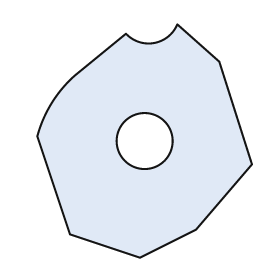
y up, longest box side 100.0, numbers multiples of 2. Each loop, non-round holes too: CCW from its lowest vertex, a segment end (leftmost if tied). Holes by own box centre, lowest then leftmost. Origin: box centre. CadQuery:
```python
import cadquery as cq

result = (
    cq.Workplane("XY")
    .moveTo(-2.0, -50.0)
    .lineTo(22.0, -38.0)
    .lineTo(46.0, -10.0)
    .lineTo(32.0, 34.0)
    .lineTo(14.0, 50.0)
    .threePointArc((4.0, 42.0), (-8.0, 46.0))
    .lineTo(-30.0, 28.0)
    .threePointArc((-40.0, 16.0), (-46.0, 2.0))
    .lineTo(-32.0, -40.0)
    .close()
    .moveTo(0.0, 0.0)
    .circle(12.0)
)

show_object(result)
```